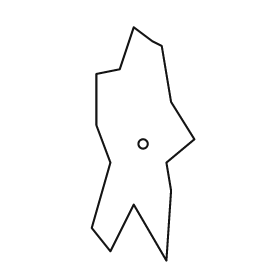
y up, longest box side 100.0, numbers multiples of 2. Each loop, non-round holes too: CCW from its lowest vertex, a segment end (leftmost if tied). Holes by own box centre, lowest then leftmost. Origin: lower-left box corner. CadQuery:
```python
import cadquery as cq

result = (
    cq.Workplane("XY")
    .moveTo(32.0, 0.0)
    .lineTo(34.0, 30.0)
    .lineTo(32.0, 42.0)
    .lineTo(44.0, 52.0)
    .lineTo(34.0, 68.0)
    .lineTo(30.0, 92.0)
    .lineTo(26.0, 94.0)
    .lineTo(18.0, 100.0)
    .lineTo(12.0, 82.0)
    .lineTo(2.0, 80.0)
    .lineTo(2.0, 58.0)
    .lineTo(8.0, 42.0)
    .lineTo(0.0, 14.0)
    .lineTo(8.0, 4.0)
    .lineTo(18.0, 24.0)
    .close()
    .moveTo(22.0, 50.0)
    .circle(2.0)
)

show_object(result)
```